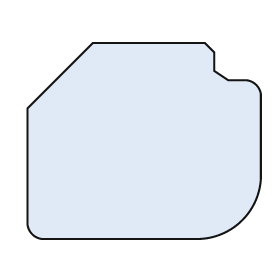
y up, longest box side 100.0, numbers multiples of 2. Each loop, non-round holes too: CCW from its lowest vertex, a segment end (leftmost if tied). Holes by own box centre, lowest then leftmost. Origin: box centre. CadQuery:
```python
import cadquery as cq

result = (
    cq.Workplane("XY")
    .moveTo(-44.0, -42.0)
    .lineTo(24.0, -42.0)
    .threePointArc((42.0, -34.0), (50.0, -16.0))
    .lineTo(50.0, 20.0)
    .threePointArc((48.0, 24.0), (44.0, 26.0))
    .lineTo(36.0, 26.0)
    .lineTo(30.0, 30.0)
    .lineTo(30.0, 38.0)
    .lineTo(26.0, 42.0)
    .lineTo(-22.0, 42.0)
    .lineTo(-50.0, 14.0)
    .lineTo(-50.0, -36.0)
    .threePointArc((-48.0, -40.0), (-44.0, -42.0))
    .close()
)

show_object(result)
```